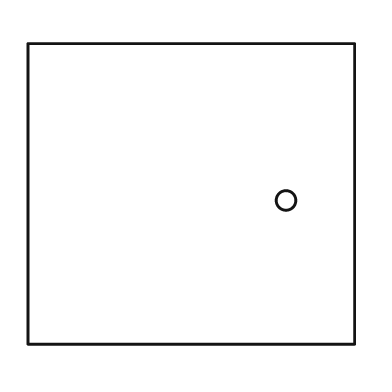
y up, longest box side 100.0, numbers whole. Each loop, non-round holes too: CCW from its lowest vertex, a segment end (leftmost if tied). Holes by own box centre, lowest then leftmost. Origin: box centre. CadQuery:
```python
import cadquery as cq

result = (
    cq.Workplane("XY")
    .moveTo(-50.0, -46.0)
    .lineTo(50.0, -46.0)
    .lineTo(50.0, 46.0)
    .lineTo(-50.0, 46.0)
    .close()
    .moveTo(29.0, -2.0)
    .circle(3.0)
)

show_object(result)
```